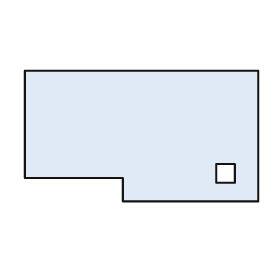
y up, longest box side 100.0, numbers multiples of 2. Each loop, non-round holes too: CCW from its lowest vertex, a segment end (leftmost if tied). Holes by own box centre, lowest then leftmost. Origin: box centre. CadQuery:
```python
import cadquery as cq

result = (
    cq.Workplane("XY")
    .moveTo(-8.0, -28.0)
    .lineTo(50.0, -28.0)
    .lineTo(50.0, 28.0)
    .lineTo(-50.0, 28.0)
    .lineTo(-50.0, -18.0)
    .lineTo(-8.0, -18.0)
    .close()
    .moveTo(32.0, -20.0)
    .lineTo(40.0, -20.0)
    .lineTo(40.0, -12.0)
    .lineTo(32.0, -12.0)
    .close()
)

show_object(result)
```